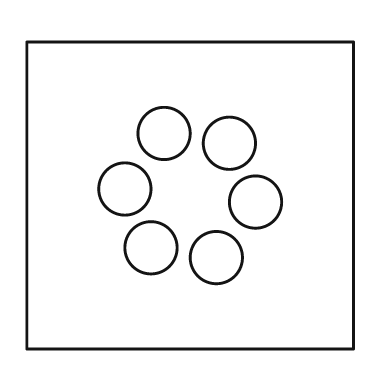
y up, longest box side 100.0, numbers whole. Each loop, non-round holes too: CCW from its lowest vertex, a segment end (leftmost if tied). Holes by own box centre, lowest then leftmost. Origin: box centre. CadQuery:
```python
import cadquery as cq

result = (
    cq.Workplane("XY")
    .moveTo(-50.0, -47.0)
    .lineTo(50.0, -47.0)
    .lineTo(50.0, 47.0)
    .lineTo(-50.0, 47.0)
    .close()
    .moveTo(8.0, -19.0)
    .circle(8.0)
    .moveTo(-12.0, -16.0)
    .circle(8.0)
    .moveTo(20.0, -2.0)
    .circle(8.0)
    .moveTo(-20.0, 2.0)
    .circle(8.0)
    .moveTo(12.0, 16.0)
    .circle(8.0)
    .moveTo(-8.0, 19.0)
    .circle(8.0)
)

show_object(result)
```